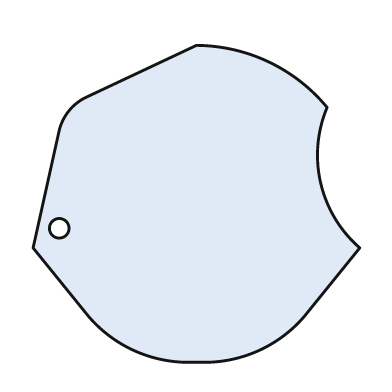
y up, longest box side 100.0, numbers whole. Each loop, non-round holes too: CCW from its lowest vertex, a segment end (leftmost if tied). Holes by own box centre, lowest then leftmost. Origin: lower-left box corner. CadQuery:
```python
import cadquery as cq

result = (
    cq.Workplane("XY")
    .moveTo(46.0, 0.0)
    .lineTo(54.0, 0.0)
    .threePointArc((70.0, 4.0), (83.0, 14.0))
    .lineTo(100.0, 35.0)
    .threePointArc((88.0, 55.0), (90.0, 78.0))
    .threePointArc((72.0, 92.0), (50.0, 97.0))
    .lineTo(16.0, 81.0)
    .threePointArc((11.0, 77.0), (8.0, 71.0))
    .lineTo(0.0, 35.0)
    .lineTo(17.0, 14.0)
    .threePointArc((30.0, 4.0), (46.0, 0.0))
    .close()
    .moveTo(8.0, 41.0)
    .circle(3.0)
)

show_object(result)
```